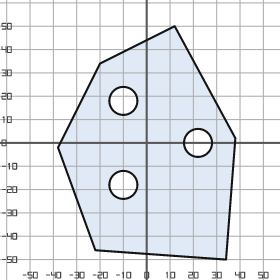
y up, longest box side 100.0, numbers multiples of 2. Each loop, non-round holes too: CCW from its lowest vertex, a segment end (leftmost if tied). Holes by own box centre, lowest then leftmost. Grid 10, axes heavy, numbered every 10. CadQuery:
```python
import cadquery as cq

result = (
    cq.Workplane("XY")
    .moveTo(34.0, -50.0)
    .lineTo(38.0, 2.0)
    .lineTo(12.0, 50.0)
    .lineTo(-20.0, 34.0)
    .lineTo(-38.0, -2.0)
    .lineTo(-22.0, -46.0)
    .close()
    .moveTo(-10.0, -18.0)
    .circle(6.0)
    .moveTo(22.0, 0.0)
    .circle(6.0)
    .moveTo(-10.0, 18.0)
    .circle(6.0)
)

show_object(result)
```